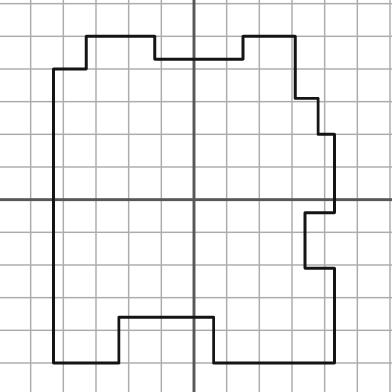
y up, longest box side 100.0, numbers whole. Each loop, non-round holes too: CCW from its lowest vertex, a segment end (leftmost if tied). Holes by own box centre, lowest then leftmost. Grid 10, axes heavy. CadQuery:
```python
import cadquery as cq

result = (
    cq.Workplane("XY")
    .moveTo(-43.0, -50.0)
    .lineTo(-23.0, -50.0)
    .lineTo(-23.0, -36.0)
    .lineTo(6.0, -36.0)
    .lineTo(6.0, -50.0)
    .lineTo(43.0, -50.0)
    .lineTo(43.0, -21.0)
    .lineTo(34.0, -21.0)
    .lineTo(34.0, -4.0)
    .lineTo(43.0, -4.0)
    .lineTo(43.0, 20.0)
    .lineTo(38.0, 20.0)
    .lineTo(38.0, 31.0)
    .lineTo(31.0, 31.0)
    .lineTo(31.0, 50.0)
    .lineTo(15.0, 50.0)
    .lineTo(15.0, 43.0)
    .lineTo(-12.0, 43.0)
    .lineTo(-12.0, 50.0)
    .lineTo(-33.0, 50.0)
    .lineTo(-33.0, 40.0)
    .lineTo(-43.0, 40.0)
    .close()
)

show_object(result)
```